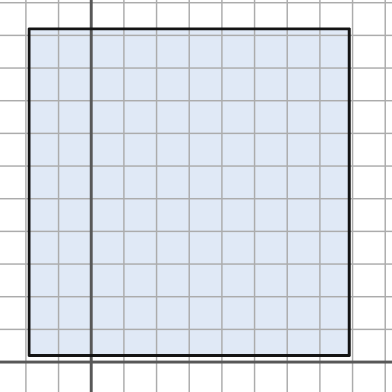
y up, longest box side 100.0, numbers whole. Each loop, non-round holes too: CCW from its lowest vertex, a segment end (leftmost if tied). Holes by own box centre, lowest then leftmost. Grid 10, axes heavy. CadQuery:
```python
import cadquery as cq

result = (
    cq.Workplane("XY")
    .moveTo(-19.0, 2.0)
    .lineTo(79.0, 2.0)
    .lineTo(79.0, 102.0)
    .lineTo(-19.0, 102.0)
    .close()
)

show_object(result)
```